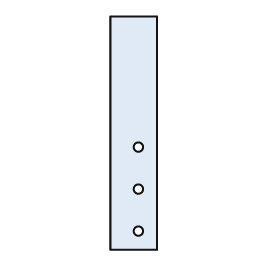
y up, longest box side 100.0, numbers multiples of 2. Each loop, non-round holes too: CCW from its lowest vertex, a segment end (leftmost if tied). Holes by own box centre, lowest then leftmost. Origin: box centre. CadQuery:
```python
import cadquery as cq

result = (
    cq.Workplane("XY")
    .moveTo(-10.0, -50.0)
    .lineTo(10.0, -50.0)
    .lineTo(10.0, 50.0)
    .lineTo(-10.0, 50.0)
    .close()
    .moveTo(2.0, -42.0)
    .circle(2.0)
    .moveTo(2.0, -24.0)
    .circle(2.0)
    .moveTo(2.0, -6.0)
    .circle(2.0)
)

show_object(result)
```